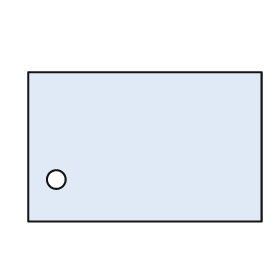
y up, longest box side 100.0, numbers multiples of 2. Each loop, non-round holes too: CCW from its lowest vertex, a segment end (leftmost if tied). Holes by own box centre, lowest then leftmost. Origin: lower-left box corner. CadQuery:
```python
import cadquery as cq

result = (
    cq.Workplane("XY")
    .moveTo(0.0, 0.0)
    .lineTo(100.0, 0.0)
    .lineTo(100.0, 64.0)
    .lineTo(0.0, 64.0)
    .close()
    .moveTo(12.0, 18.0)
    .circle(4.0)
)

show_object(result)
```